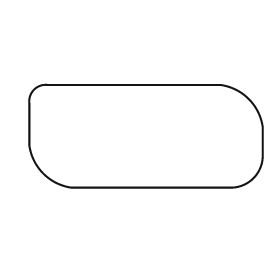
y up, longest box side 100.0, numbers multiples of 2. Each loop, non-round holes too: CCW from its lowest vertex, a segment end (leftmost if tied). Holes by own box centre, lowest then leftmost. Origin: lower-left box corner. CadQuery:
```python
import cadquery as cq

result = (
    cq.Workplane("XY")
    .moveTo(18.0, 0.0)
    .lineTo(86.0, 0.0)
    .threePointArc((96.0, 4.0), (100.0, 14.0))
    .lineTo(100.0, 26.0)
    .threePointArc((94.0, 38.0), (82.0, 44.0))
    .lineTo(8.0, 44.0)
    .threePointArc((2.0, 42.0), (0.0, 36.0))
    .lineTo(0.0, 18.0)
    .threePointArc((6.0, 6.0), (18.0, 0.0))
    .close()
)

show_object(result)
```